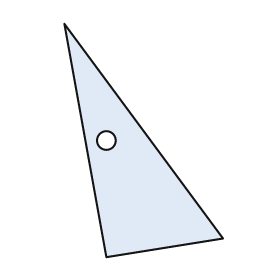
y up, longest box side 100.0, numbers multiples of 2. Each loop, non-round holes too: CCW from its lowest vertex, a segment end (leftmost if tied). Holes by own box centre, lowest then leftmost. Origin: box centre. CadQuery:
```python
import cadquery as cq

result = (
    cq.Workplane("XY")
    .moveTo(-16.0, -50.0)
    .lineTo(34.0, -42.0)
    .lineTo(-34.0, 50.0)
    .close()
    .moveTo(-16.0, 0.0)
    .circle(4.0)
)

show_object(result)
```